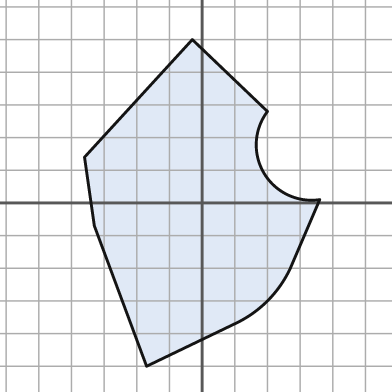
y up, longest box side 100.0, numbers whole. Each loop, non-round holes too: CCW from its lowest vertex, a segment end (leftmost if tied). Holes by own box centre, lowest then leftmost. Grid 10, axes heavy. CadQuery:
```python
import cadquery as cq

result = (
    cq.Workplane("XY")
    .moveTo(-17.0, -50.0)
    .lineTo(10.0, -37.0)
    .threePointArc((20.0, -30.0), (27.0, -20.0))
    .lineTo(36.0, 1.0)
    .threePointArc((19.0, 9.0), (20.0, 28.0))
    .lineTo(-3.0, 50.0)
    .lineTo(-36.0, 14.0)
    .lineTo(-33.0, -7.0)
    .close()
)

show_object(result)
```